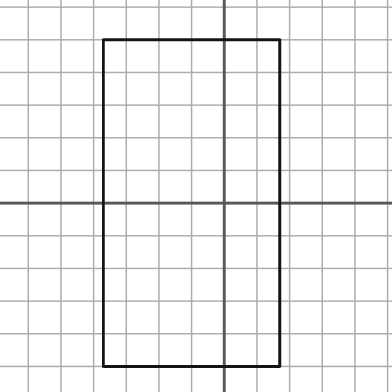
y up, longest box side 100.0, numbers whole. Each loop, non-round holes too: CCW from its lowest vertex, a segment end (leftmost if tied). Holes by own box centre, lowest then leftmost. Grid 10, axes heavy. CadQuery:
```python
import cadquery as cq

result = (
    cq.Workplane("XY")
    .moveTo(-37.0, -50.0)
    .lineTo(17.0, -50.0)
    .lineTo(17.0, 50.0)
    .lineTo(-37.0, 50.0)
    .close()
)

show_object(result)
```